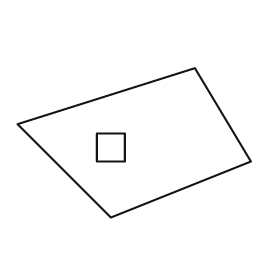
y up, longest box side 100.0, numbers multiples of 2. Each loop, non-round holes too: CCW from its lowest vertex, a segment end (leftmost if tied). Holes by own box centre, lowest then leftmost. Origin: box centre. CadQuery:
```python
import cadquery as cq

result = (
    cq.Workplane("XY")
    .moveTo(-10.0, -32.0)
    .lineTo(50.0, -8.0)
    .lineTo(26.0, 32.0)
    .lineTo(-50.0, 8.0)
    .close()
    .moveTo(-16.0, -8.0)
    .lineTo(-4.0, -8.0)
    .lineTo(-4.0, 4.0)
    .lineTo(-16.0, 4.0)
    .close()
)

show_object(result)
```